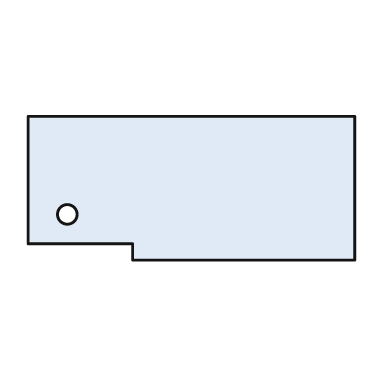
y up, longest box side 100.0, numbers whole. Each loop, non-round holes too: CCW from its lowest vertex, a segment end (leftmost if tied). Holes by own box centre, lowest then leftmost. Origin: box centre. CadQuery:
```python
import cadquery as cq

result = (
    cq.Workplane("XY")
    .moveTo(-18.0, -22.0)
    .lineTo(50.0, -22.0)
    .lineTo(50.0, 22.0)
    .lineTo(-50.0, 22.0)
    .lineTo(-50.0, -17.0)
    .lineTo(-18.0, -17.0)
    .close()
    .moveTo(-38.0, -8.0)
    .circle(3.0)
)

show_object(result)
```